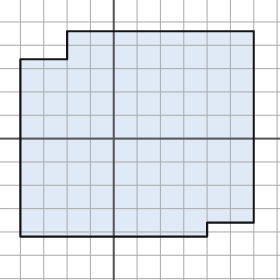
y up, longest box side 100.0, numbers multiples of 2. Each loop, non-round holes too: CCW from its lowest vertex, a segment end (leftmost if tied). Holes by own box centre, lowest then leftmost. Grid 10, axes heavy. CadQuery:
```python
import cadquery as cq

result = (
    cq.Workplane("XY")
    .moveTo(-40.0, -42.0)
    .lineTo(40.0, -42.0)
    .lineTo(40.0, -36.0)
    .lineTo(60.0, -36.0)
    .lineTo(60.0, 46.0)
    .lineTo(-20.0, 46.0)
    .lineTo(-20.0, 34.0)
    .lineTo(-40.0, 34.0)
    .close()
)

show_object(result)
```